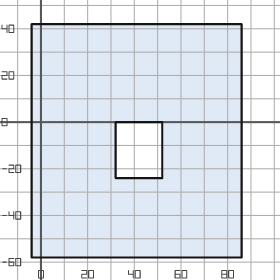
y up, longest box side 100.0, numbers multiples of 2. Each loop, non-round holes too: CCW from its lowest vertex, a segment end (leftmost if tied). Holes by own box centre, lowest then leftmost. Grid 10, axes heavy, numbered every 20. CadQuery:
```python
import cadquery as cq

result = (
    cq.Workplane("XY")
    .moveTo(-4.0, -58.0)
    .lineTo(86.0, -58.0)
    .lineTo(86.0, 42.0)
    .lineTo(-4.0, 42.0)
    .close()
    .moveTo(32.0, -24.0)
    .lineTo(52.0, -24.0)
    .lineTo(52.0, 0.0)
    .lineTo(32.0, 0.0)
    .close()
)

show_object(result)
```